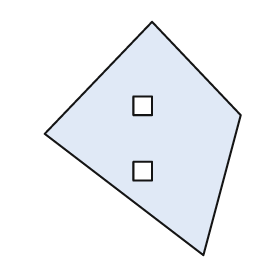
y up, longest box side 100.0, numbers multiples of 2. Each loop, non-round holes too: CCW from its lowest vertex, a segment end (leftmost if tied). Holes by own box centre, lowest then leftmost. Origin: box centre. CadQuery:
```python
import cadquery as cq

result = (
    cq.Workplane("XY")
    .moveTo(26.0, -50.0)
    .lineTo(42.0, 10.0)
    .lineTo(4.0, 50.0)
    .lineTo(-42.0, 2.0)
    .close()
    .moveTo(-4.0, -18.0)
    .lineTo(4.0, -18.0)
    .lineTo(4.0, -10.0)
    .lineTo(-4.0, -10.0)
    .close()
    .moveTo(-4.0, 10.0)
    .lineTo(4.0, 10.0)
    .lineTo(4.0, 18.0)
    .lineTo(-4.0, 18.0)
    .close()
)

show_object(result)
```